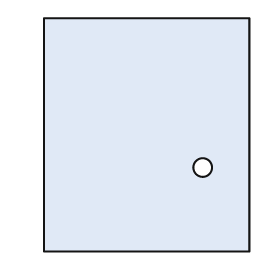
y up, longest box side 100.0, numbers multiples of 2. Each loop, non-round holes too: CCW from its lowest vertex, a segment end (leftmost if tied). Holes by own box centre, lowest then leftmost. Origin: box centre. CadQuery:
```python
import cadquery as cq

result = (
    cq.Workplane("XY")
    .moveTo(-44.0, -50.0)
    .lineTo(44.0, -50.0)
    .lineTo(44.0, 50.0)
    .lineTo(-44.0, 50.0)
    .close()
    .moveTo(24.0, -14.0)
    .circle(4.0)
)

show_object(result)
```